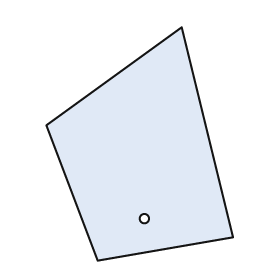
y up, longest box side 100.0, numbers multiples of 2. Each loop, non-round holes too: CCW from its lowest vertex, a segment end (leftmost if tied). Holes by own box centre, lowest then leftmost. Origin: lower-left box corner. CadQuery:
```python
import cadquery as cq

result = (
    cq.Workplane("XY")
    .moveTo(22.0, 0.0)
    .lineTo(80.0, 10.0)
    .lineTo(58.0, 100.0)
    .lineTo(0.0, 58.0)
    .close()
    .moveTo(42.0, 18.0)
    .circle(2.0)
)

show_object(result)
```